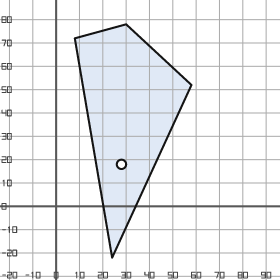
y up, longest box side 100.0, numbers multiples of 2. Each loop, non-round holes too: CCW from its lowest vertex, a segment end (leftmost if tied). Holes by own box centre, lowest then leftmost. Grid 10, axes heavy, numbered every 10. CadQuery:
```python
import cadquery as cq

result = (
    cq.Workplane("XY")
    .moveTo(24.0, -22.0)
    .lineTo(58.0, 52.0)
    .lineTo(30.0, 78.0)
    .lineTo(8.0, 72.0)
    .close()
    .moveTo(28.0, 18.0)
    .circle(2.0)
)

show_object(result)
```